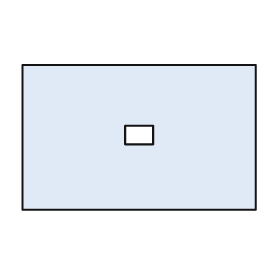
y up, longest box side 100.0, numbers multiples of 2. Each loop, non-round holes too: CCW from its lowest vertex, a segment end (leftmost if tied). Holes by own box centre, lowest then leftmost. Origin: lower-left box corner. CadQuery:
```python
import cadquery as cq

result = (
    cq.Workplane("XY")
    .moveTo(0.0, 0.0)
    .lineTo(100.0, 0.0)
    .lineTo(100.0, 62.0)
    .lineTo(0.0, 62.0)
    .close()
    .moveTo(44.0, 28.0)
    .lineTo(56.0, 28.0)
    .lineTo(56.0, 36.0)
    .lineTo(44.0, 36.0)
    .close()
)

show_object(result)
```